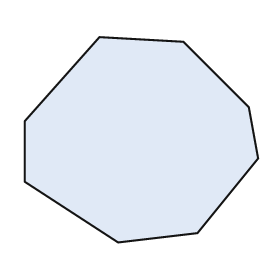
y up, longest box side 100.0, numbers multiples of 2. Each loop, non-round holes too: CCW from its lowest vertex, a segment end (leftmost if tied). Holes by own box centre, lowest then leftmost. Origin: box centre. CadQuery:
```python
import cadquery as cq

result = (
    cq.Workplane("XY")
    .moveTo(-10.0, -44.0)
    .lineTo(24.0, -40.0)
    .lineTo(50.0, -8.0)
    .lineTo(46.0, 14.0)
    .lineTo(18.0, 42.0)
    .lineTo(-18.0, 44.0)
    .lineTo(-50.0, 8.0)
    .lineTo(-50.0, -18.0)
    .close()
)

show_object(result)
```